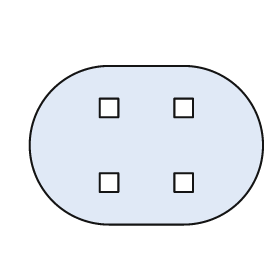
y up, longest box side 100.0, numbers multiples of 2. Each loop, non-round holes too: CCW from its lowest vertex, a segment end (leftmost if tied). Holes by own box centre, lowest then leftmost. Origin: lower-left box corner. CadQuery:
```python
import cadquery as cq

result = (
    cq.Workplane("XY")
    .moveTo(34.0, 0.0)
    .lineTo(66.0, 0.0)
    .threePointArc((100.0, 34.0), (66.0, 68.0))
    .lineTo(34.0, 68.0)
    .threePointArc((0.0, 34.0), (34.0, 0.0))
    .close()
    .moveTo(30.0, 14.0)
    .lineTo(38.0, 14.0)
    .lineTo(38.0, 22.0)
    .lineTo(30.0, 22.0)
    .close()
    .moveTo(62.0, 14.0)
    .lineTo(70.0, 14.0)
    .lineTo(70.0, 22.0)
    .lineTo(62.0, 22.0)
    .close()
    .moveTo(30.0, 46.0)
    .lineTo(38.0, 46.0)
    .lineTo(38.0, 54.0)
    .lineTo(30.0, 54.0)
    .close()
    .moveTo(62.0, 46.0)
    .lineTo(70.0, 46.0)
    .lineTo(70.0, 54.0)
    .lineTo(62.0, 54.0)
    .close()
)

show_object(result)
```